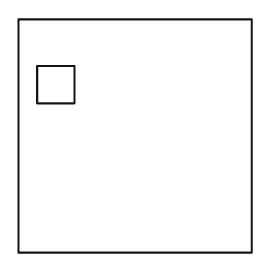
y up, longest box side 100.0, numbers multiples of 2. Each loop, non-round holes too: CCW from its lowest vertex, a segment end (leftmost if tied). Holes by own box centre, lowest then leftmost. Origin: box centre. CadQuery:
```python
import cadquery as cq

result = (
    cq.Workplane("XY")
    .moveTo(-50.0, -50.0)
    .lineTo(50.0, -50.0)
    .lineTo(50.0, 50.0)
    .lineTo(-50.0, 50.0)
    .close()
    .moveTo(-42.0, 14.0)
    .lineTo(-26.0, 14.0)
    .lineTo(-26.0, 30.0)
    .lineTo(-42.0, 30.0)
    .close()
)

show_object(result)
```